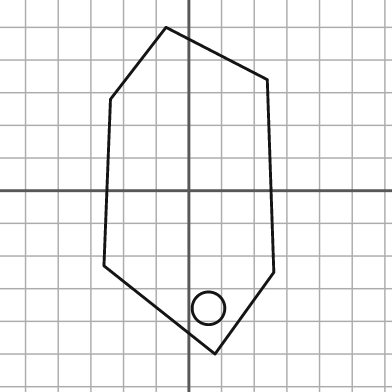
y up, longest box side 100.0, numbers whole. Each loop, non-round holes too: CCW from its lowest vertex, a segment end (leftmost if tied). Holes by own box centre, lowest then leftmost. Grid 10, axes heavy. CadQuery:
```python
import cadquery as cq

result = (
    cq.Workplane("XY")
    .moveTo(8.0, -50.0)
    .lineTo(26.0, -25.0)
    .lineTo(24.0, 34.0)
    .lineTo(-7.0, 50.0)
    .lineTo(-24.0, 28.0)
    .lineTo(-26.0, -23.0)
    .close()
    .moveTo(6.0, -36.0)
    .circle(5.0)
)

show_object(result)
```